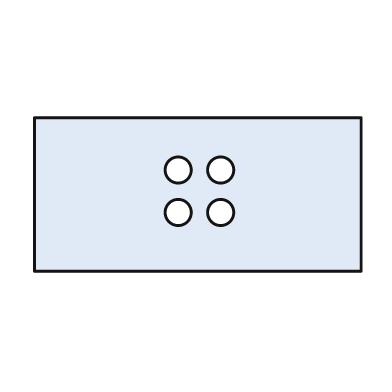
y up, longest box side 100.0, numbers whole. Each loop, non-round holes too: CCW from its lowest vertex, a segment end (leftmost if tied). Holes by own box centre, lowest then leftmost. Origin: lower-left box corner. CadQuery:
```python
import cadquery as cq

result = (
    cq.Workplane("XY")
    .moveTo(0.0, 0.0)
    .lineTo(100.0, 0.0)
    .lineTo(100.0, 47.0)
    .lineTo(0.0, 47.0)
    .close()
    .moveTo(44.0, 18.0)
    .circle(4.0)
    .moveTo(57.0, 18.0)
    .circle(4.0)
    .moveTo(44.0, 31.0)
    .circle(4.0)
    .moveTo(57.0, 31.0)
    .circle(4.0)
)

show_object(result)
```